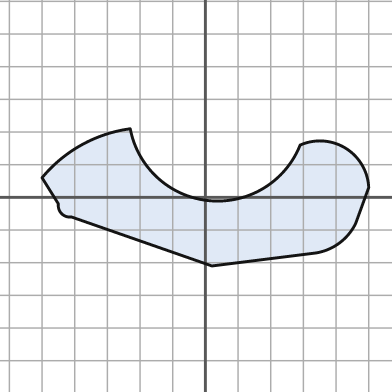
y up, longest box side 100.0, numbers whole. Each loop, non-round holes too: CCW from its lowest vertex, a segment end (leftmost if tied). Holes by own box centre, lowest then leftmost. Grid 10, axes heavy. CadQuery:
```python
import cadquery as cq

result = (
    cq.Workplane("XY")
    .moveTo(2.0, -21.0)
    .lineTo(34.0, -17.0)
    .threePointArc((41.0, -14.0), (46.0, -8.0))
    .lineTo(50.0, 3.0)
    .threePointArc((43.0, 15.0), (29.0, 16.0))
    .threePointArc((1.0, -1.0), (-23.0, 21.0))
    .threePointArc((-38.0, 16.0), (-50.0, 6.0))
    .lineTo(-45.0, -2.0)
    .threePointArc((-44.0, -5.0), (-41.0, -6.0))
    .close()
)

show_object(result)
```